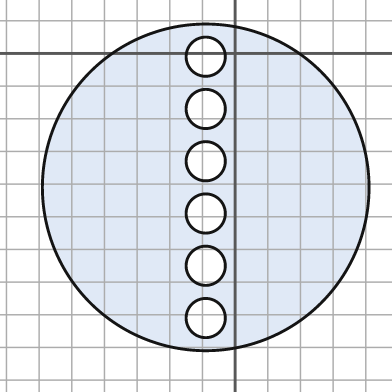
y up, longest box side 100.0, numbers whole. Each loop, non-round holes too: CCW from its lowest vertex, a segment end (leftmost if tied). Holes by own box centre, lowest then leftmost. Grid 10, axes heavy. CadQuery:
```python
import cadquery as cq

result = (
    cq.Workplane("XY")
    .moveTo(-9.0, -41.0)
    .circle(50.0)
    .moveTo(-9.0, -81.0)
    .circle(6.0)
    .moveTo(-9.0, -65.0)
    .circle(6.0)
    .moveTo(-9.0, -49.0)
    .circle(6.0)
    .moveTo(-9.0, -33.0)
    .circle(6.0)
    .moveTo(-9.0, -17.0)
    .circle(6.0)
    .moveTo(-9.0, -1.0)
    .circle(6.0)
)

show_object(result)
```